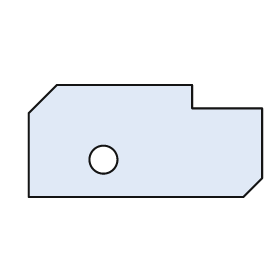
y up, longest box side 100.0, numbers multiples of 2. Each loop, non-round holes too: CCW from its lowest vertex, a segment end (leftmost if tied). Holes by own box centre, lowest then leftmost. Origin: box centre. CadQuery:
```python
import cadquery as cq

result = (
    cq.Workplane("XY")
    .moveTo(-50.0, -24.0)
    .lineTo(42.0, -24.0)
    .lineTo(50.0, -16.0)
    .lineTo(50.0, 14.0)
    .lineTo(20.0, 14.0)
    .lineTo(20.0, 24.0)
    .lineTo(-38.0, 24.0)
    .lineTo(-50.0, 12.0)
    .close()
    .moveTo(-18.0, -8.0)
    .circle(6.0)
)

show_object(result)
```